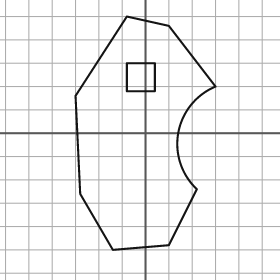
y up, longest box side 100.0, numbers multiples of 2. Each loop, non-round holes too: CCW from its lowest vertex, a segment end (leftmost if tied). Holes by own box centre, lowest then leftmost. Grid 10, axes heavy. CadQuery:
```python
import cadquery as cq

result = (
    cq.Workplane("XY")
    .moveTo(-14.0, -50.0)
    .lineTo(10.0, -48.0)
    .lineTo(22.0, -24.0)
    .threePointArc((14.0, 0.0), (30.0, 20.0))
    .lineTo(10.0, 46.0)
    .lineTo(-8.0, 50.0)
    .lineTo(-30.0, 16.0)
    .lineTo(-28.0, -26.0)
    .close()
    .moveTo(-8.0, 18.0)
    .lineTo(4.0, 18.0)
    .lineTo(4.0, 30.0)
    .lineTo(-8.0, 30.0)
    .close()
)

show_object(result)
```